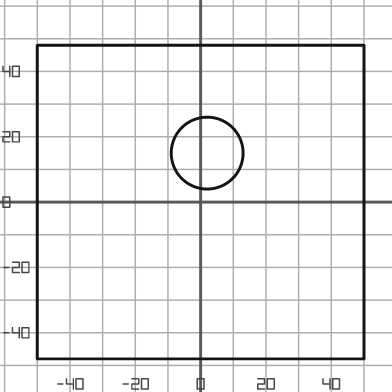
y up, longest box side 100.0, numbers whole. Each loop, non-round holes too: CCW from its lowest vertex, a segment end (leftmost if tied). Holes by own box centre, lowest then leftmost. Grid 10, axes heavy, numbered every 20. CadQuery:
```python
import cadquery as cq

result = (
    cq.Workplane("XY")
    .moveTo(-50.0, -48.0)
    .lineTo(50.0, -48.0)
    .lineTo(50.0, 48.0)
    .lineTo(-50.0, 48.0)
    .close()
    .moveTo(2.0, 15.0)
    .circle(11.0)
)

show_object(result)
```